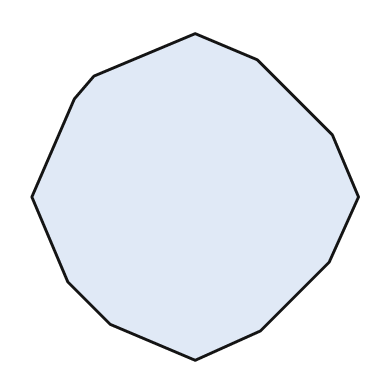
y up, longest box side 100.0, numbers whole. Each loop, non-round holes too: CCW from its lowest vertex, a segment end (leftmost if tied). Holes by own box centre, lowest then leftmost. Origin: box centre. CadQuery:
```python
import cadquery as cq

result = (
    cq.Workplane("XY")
    .moveTo(0.0, -50.0)
    .lineTo(20.0, -41.0)
    .lineTo(41.0, -20.0)
    .lineTo(50.0, 0.0)
    .lineTo(42.0, 19.0)
    .lineTo(19.0, 42.0)
    .lineTo(0.0, 50.0)
    .lineTo(-31.0, 37.0)
    .lineTo(-37.0, 30.0)
    .lineTo(-50.0, 0.0)
    .lineTo(-39.0, -26.0)
    .lineTo(-26.0, -39.0)
    .close()
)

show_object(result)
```